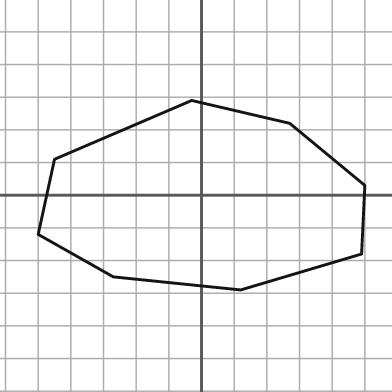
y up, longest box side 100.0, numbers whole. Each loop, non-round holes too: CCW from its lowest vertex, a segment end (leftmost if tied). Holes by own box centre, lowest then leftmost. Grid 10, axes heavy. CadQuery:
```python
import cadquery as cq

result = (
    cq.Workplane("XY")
    .moveTo(12.0, -29.0)
    .lineTo(49.0, -18.0)
    .lineTo(50.0, 3.0)
    .lineTo(27.0, 22.0)
    .lineTo(-3.0, 29.0)
    .lineTo(-45.0, 11.0)
    .lineTo(-50.0, -12.0)
    .lineTo(-27.0, -25.0)
    .close()
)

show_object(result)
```